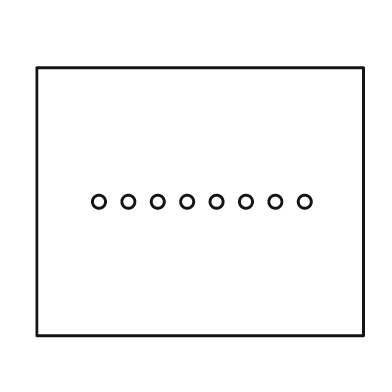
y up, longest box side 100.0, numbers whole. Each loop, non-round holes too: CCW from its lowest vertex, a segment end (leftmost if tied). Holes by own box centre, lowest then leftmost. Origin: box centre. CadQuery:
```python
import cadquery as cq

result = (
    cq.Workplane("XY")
    .moveTo(-50.0, -41.0)
    .lineTo(50.0, -41.0)
    .lineTo(50.0, 41.0)
    .lineTo(-50.0, 41.0)
    .close()
    .moveTo(-31.0, 0.0)
    .circle(2.0)
    .moveTo(-22.0, 0.0)
    .circle(2.0)
    .moveTo(-13.0, 0.0)
    .circle(2.0)
    .moveTo(-4.0, 0.0)
    .circle(2.0)
    .moveTo(5.0, 0.0)
    .circle(2.0)
    .moveTo(14.0, 0.0)
    .circle(2.0)
    .moveTo(23.0, 0.0)
    .circle(2.0)
    .moveTo(32.0, 0.0)
    .circle(2.0)
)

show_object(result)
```